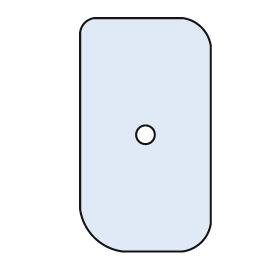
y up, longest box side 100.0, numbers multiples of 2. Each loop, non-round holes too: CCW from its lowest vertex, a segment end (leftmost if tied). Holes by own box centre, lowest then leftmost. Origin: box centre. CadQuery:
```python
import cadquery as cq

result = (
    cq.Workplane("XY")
    .moveTo(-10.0, -50.0)
    .lineTo(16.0, -50.0)
    .threePointArc((24.0, -46.0), (28.0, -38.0))
    .lineTo(28.0, 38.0)
    .threePointArc((24.0, 46.0), (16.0, 50.0))
    .lineTo(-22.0, 50.0)
    .threePointArc((-26.0, 48.0), (-28.0, 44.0))
    .lineTo(-28.0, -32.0)
    .threePointArc((-22.0, -44.0), (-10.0, -50.0))
    .close()
    .moveTo(0.0, 0.0)
    .circle(4.0)
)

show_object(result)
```